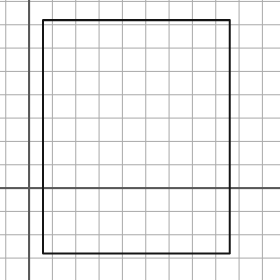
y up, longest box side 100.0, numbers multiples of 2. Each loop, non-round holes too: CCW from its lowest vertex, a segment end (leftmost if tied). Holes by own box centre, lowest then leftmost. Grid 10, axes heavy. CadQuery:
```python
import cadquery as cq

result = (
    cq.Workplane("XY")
    .moveTo(6.0, -28.0)
    .lineTo(86.0, -28.0)
    .lineTo(86.0, 72.0)
    .lineTo(6.0, 72.0)
    .close()
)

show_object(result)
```